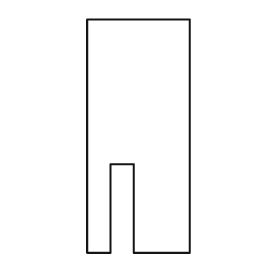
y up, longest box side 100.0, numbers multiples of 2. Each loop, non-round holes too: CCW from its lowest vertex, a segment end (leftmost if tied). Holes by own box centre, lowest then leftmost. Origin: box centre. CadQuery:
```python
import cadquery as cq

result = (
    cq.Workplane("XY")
    .moveTo(-22.0, -50.0)
    .lineTo(-12.0, -50.0)
    .lineTo(-12.0, -12.0)
    .lineTo(-2.0, -12.0)
    .lineTo(-2.0, -50.0)
    .lineTo(22.0, -50.0)
    .lineTo(22.0, 50.0)
    .lineTo(-22.0, 50.0)
    .close()
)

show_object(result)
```